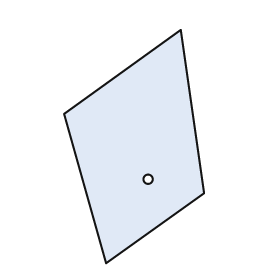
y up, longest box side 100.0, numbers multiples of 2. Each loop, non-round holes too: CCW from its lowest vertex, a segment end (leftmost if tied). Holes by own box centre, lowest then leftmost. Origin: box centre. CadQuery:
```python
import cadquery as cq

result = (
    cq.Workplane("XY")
    .moveTo(-12.0, -50.0)
    .lineTo(30.0, -20.0)
    .lineTo(20.0, 50.0)
    .lineTo(-30.0, 14.0)
    .close()
    .moveTo(6.0, -14.0)
    .circle(2.0)
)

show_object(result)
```